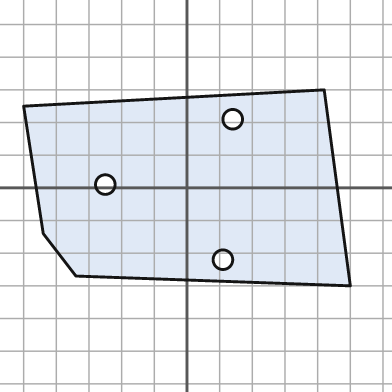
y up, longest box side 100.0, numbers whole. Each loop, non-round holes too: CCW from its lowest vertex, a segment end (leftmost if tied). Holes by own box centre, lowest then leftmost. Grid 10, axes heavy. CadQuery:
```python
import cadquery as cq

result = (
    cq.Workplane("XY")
    .moveTo(50.0, -30.0)
    .lineTo(42.0, 30.0)
    .lineTo(-50.0, 25.0)
    .lineTo(-44.0, -14.0)
    .lineTo(-34.0, -27.0)
    .close()
    .moveTo(11.0, -22.0)
    .circle(3.0)
    .moveTo(-25.0, 1.0)
    .circle(3.0)
    .moveTo(14.0, 21.0)
    .circle(3.0)
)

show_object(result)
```